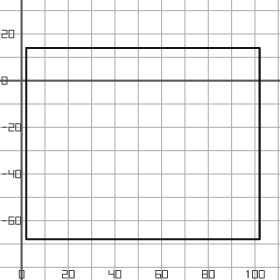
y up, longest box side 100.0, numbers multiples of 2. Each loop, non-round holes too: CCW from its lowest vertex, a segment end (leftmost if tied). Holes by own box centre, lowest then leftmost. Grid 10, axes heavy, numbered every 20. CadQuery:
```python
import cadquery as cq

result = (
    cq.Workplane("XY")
    .moveTo(2.0, -68.0)
    .lineTo(102.0, -68.0)
    .lineTo(102.0, 14.0)
    .lineTo(2.0, 14.0)
    .close()
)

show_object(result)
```